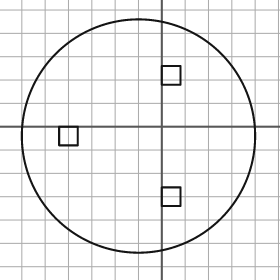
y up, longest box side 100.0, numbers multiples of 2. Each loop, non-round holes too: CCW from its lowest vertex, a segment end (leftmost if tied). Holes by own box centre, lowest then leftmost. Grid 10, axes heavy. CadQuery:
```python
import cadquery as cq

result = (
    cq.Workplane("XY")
    .moveTo(-10.0, -4.0)
    .circle(50.0)
    .moveTo(0.0, -34.0)
    .lineTo(8.0, -34.0)
    .lineTo(8.0, -26.0)
    .lineTo(0.0, -26.0)
    .close()
    .moveTo(-44.0, -8.0)
    .lineTo(-36.0, -8.0)
    .lineTo(-36.0, 0.0)
    .lineTo(-44.0, 0.0)
    .close()
    .moveTo(0.0, 18.0)
    .lineTo(8.0, 18.0)
    .lineTo(8.0, 26.0)
    .lineTo(0.0, 26.0)
    .close()
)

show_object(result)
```